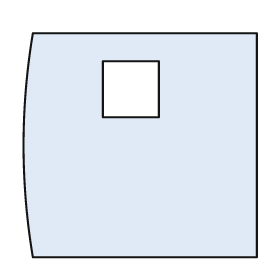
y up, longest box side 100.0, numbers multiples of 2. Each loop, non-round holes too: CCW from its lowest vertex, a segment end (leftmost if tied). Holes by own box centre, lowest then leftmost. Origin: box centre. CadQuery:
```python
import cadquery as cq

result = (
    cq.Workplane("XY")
    .moveTo(-46.0, -48.0)
    .lineTo(50.0, -48.0)
    .lineTo(50.0, 48.0)
    .lineTo(-46.0, 48.0)
    .threePointArc((-50.0, 0.0), (-46.0, -48.0))
    .close()
    .moveTo(-16.0, 12.0)
    .lineTo(8.0, 12.0)
    .lineTo(8.0, 36.0)
    .lineTo(-16.0, 36.0)
    .close()
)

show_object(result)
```